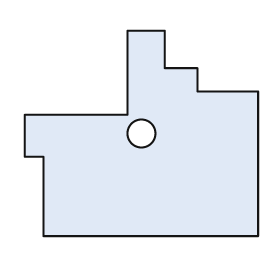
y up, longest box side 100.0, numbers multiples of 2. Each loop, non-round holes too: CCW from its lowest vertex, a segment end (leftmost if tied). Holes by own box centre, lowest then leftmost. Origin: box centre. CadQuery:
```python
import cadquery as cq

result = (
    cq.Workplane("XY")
    .moveTo(-42.0, -44.0)
    .lineTo(50.0, -44.0)
    .lineTo(50.0, 18.0)
    .lineTo(24.0, 18.0)
    .lineTo(24.0, 28.0)
    .lineTo(10.0, 28.0)
    .lineTo(10.0, 44.0)
    .lineTo(-6.0, 44.0)
    .lineTo(-6.0, 8.0)
    .lineTo(-50.0, 8.0)
    .lineTo(-50.0, -10.0)
    .lineTo(-42.0, -10.0)
    .close()
    .moveTo(0.0, 0.0)
    .circle(6.0)
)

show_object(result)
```